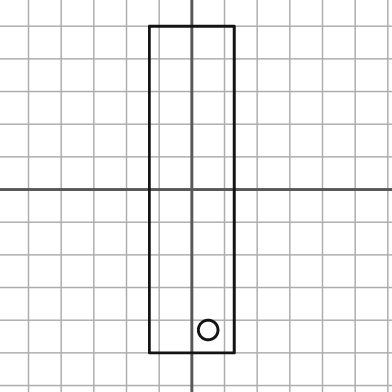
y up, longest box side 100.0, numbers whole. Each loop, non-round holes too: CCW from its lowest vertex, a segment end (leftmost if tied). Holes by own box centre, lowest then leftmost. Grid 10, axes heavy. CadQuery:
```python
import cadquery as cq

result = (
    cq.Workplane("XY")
    .moveTo(-13.0, -50.0)
    .lineTo(13.0, -50.0)
    .lineTo(13.0, 50.0)
    .lineTo(-13.0, 50.0)
    .close()
    .moveTo(5.0, -43.0)
    .circle(3.0)
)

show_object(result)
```